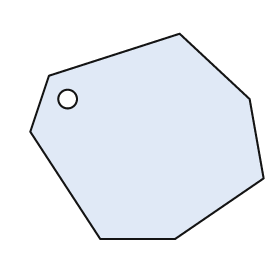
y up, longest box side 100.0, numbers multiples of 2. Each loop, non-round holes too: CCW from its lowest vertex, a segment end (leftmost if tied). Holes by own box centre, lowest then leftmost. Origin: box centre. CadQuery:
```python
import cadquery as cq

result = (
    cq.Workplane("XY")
    .moveTo(-20.0, -44.0)
    .lineTo(12.0, -44.0)
    .lineTo(50.0, -18.0)
    .lineTo(44.0, 16.0)
    .lineTo(14.0, 44.0)
    .lineTo(-42.0, 26.0)
    .lineTo(-50.0, 2.0)
    .close()
    .moveTo(-34.0, 16.0)
    .circle(4.0)
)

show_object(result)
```